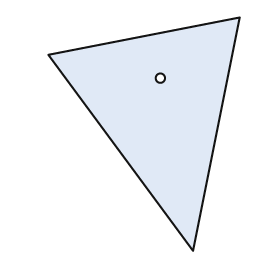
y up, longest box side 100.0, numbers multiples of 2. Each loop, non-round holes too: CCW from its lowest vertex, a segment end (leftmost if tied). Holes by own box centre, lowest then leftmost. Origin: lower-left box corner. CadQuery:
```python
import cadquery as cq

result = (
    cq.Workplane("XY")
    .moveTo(62.0, 0.0)
    .lineTo(82.0, 100.0)
    .lineTo(0.0, 84.0)
    .close()
    .moveTo(48.0, 74.0)
    .circle(2.0)
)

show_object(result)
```